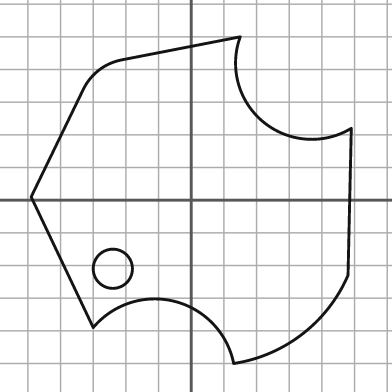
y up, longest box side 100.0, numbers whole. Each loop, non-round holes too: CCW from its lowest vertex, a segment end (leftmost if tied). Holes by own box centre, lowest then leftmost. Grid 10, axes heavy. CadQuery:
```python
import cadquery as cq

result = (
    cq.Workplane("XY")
    .moveTo(13.0, -50.0)
    .threePointArc((34.0, -41.0), (48.0, -23.0))
    .lineTo(49.0, 22.0)
    .threePointArc((22.0, 24.0), (15.0, 50.0))
    .lineTo(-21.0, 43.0)
    .threePointArc((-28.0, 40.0), (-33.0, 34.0))
    .lineTo(-49.0, 1.0)
    .lineTo(-30.0, -39.0)
    .threePointArc((-5.0, -31.0), (13.0, -50.0))
    .close()
    .moveTo(-24.0, -21.0)
    .circle(6.0)
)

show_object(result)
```